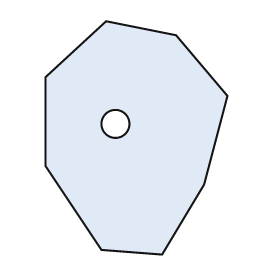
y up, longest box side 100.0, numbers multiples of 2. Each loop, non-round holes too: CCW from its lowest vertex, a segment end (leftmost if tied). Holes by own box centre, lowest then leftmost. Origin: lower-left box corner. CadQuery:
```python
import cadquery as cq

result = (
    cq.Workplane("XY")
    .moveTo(50.0, 0.0)
    .lineTo(68.0, 30.0)
    .lineTo(78.0, 68.0)
    .lineTo(56.0, 94.0)
    .lineTo(26.0, 100.0)
    .lineTo(0.0, 76.0)
    .lineTo(0.0, 38.0)
    .lineTo(24.0, 2.0)
    .close()
    .moveTo(30.0, 56.0)
    .circle(6.0)
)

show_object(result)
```